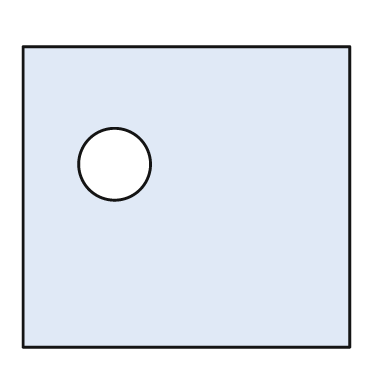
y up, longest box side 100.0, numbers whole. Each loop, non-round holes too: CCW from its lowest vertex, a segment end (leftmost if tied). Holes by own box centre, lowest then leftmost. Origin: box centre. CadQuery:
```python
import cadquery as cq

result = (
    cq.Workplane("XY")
    .moveTo(-50.0, -46.0)
    .lineTo(50.0, -46.0)
    .lineTo(50.0, 46.0)
    .lineTo(-50.0, 46.0)
    .close()
    .moveTo(-22.0, 10.0)
    .circle(11.0)
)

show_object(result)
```